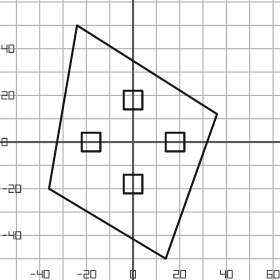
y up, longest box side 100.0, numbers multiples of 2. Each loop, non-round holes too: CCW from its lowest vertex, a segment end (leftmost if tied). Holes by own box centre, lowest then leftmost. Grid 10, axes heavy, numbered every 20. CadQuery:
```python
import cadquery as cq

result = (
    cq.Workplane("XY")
    .moveTo(14.0, -50.0)
    .lineTo(36.0, 12.0)
    .lineTo(-24.0, 50.0)
    .lineTo(-36.0, -20.0)
    .close()
    .moveTo(-4.0, -22.0)
    .lineTo(4.0, -22.0)
    .lineTo(4.0, -14.0)
    .lineTo(-4.0, -14.0)
    .close()
    .moveTo(-22.0, -4.0)
    .lineTo(-14.0, -4.0)
    .lineTo(-14.0, 4.0)
    .lineTo(-22.0, 4.0)
    .close()
    .moveTo(14.0, -4.0)
    .lineTo(22.0, -4.0)
    .lineTo(22.0, 4.0)
    .lineTo(14.0, 4.0)
    .close()
    .moveTo(-4.0, 14.0)
    .lineTo(4.0, 14.0)
    .lineTo(4.0, 22.0)
    .lineTo(-4.0, 22.0)
    .close()
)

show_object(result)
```